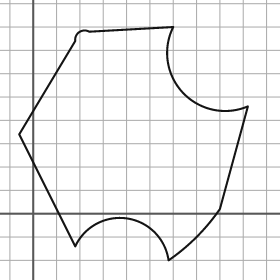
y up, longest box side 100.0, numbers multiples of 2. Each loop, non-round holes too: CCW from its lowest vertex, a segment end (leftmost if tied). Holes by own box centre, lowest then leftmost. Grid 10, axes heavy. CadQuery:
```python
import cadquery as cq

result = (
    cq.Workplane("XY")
    .moveTo(58.0, -20.0)
    .threePointArc((70.0, -10.0), (80.0, 2.0))
    .lineTo(92.0, 46.0)
    .threePointArc((64.0, 52.0), (60.0, 80.0))
    .lineTo(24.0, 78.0)
    .threePointArc((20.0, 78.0), (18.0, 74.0))
    .lineTo(-6.0, 34.0)
    .lineTo(18.0, -14.0)
    .threePointArc((40.0, -2.0), (58.0, -20.0))
    .close()
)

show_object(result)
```